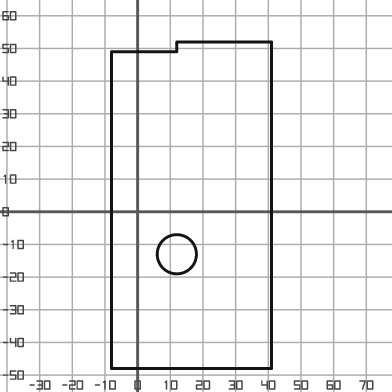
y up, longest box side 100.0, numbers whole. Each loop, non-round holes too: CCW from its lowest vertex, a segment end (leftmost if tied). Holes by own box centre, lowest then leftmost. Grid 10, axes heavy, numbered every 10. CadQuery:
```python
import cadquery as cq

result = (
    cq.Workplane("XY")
    .moveTo(-8.0, -48.0)
    .lineTo(41.0, -48.0)
    .lineTo(41.0, 52.0)
    .lineTo(12.0, 52.0)
    .lineTo(12.0, 49.0)
    .lineTo(-8.0, 49.0)
    .close()
    .moveTo(12.0, -13.0)
    .circle(6.0)
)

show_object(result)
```